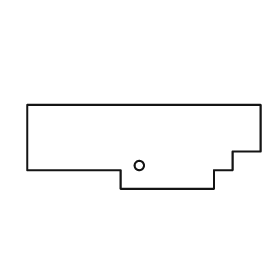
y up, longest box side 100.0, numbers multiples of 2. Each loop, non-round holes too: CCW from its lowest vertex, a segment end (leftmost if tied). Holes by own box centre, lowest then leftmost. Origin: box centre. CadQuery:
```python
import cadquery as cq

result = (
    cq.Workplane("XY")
    .moveTo(-10.0, -18.0)
    .lineTo(30.0, -18.0)
    .lineTo(30.0, -10.0)
    .lineTo(38.0, -10.0)
    .lineTo(38.0, -2.0)
    .lineTo(50.0, -2.0)
    .lineTo(50.0, 18.0)
    .lineTo(-50.0, 18.0)
    .lineTo(-50.0, -10.0)
    .lineTo(-10.0, -10.0)
    .close()
    .moveTo(-2.0, -8.0)
    .circle(2.0)
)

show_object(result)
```